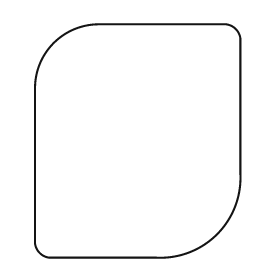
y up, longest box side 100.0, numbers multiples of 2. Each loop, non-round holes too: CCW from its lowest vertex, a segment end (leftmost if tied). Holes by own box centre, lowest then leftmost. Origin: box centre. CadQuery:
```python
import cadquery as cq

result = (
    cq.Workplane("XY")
    .moveTo(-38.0, -50.0)
    .lineTo(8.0, -50.0)
    .threePointArc((34.0, -40.0), (44.0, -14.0))
    .lineTo(44.0, 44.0)
    .threePointArc((42.0, 48.0), (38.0, 50.0))
    .lineTo(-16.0, 50.0)
    .threePointArc((-36.0, 42.0), (-44.0, 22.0))
    .lineTo(-44.0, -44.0)
    .threePointArc((-42.0, -48.0), (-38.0, -50.0))
    .close()
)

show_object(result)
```